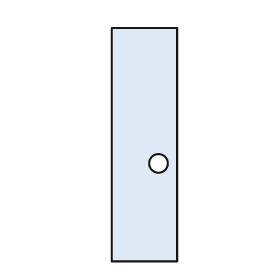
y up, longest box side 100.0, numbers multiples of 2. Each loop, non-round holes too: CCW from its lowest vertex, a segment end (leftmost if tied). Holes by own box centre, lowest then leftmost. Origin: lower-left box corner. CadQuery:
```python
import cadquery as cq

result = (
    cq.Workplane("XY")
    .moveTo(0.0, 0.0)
    .lineTo(28.0, 0.0)
    .lineTo(28.0, 100.0)
    .lineTo(0.0, 100.0)
    .close()
    .moveTo(20.0, 42.0)
    .circle(4.0)
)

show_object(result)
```